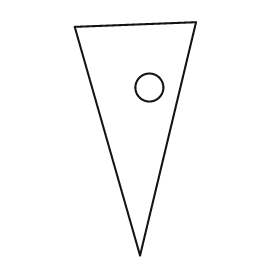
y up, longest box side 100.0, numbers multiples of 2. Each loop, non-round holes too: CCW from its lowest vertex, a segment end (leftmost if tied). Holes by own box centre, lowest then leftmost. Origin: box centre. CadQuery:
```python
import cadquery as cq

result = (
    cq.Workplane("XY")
    .moveTo(2.0, -50.0)
    .lineTo(26.0, 50.0)
    .lineTo(-26.0, 48.0)
    .close()
    .moveTo(6.0, 22.0)
    .circle(6.0)
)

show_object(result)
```